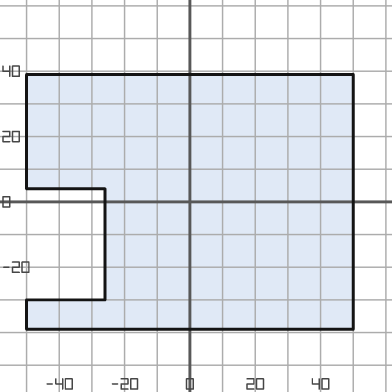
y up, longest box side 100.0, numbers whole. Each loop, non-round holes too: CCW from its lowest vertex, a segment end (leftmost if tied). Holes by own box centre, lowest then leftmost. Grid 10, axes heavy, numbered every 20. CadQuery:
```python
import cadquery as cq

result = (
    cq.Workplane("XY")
    .moveTo(-50.0, -39.0)
    .lineTo(50.0, -39.0)
    .lineTo(50.0, 39.0)
    .lineTo(-50.0, 39.0)
    .lineTo(-50.0, 4.0)
    .lineTo(-26.0, 4.0)
    .lineTo(-26.0, -30.0)
    .lineTo(-50.0, -30.0)
    .close()
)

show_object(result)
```